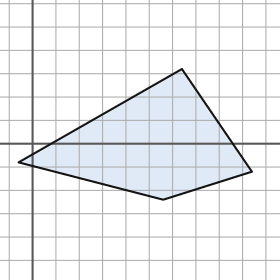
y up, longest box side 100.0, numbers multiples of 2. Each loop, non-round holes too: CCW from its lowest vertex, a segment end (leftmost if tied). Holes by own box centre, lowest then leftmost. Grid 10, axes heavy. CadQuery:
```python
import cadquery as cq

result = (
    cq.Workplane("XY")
    .moveTo(56.0, -24.0)
    .lineTo(94.0, -12.0)
    .lineTo(64.0, 32.0)
    .lineTo(-6.0, -8.0)
    .close()
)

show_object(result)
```